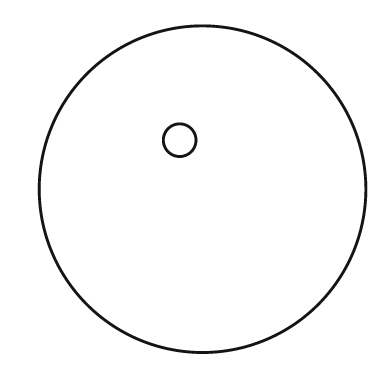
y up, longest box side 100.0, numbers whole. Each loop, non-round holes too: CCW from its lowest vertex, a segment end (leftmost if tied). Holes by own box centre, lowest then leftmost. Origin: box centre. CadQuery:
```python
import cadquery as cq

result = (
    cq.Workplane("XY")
    .moveTo(0.0, 0.0)
    .circle(50.0)
    .moveTo(-7.0, 15.0)
    .circle(5.0)
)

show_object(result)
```